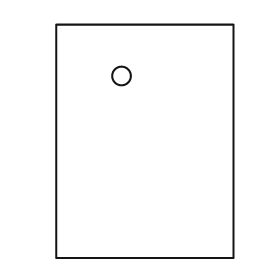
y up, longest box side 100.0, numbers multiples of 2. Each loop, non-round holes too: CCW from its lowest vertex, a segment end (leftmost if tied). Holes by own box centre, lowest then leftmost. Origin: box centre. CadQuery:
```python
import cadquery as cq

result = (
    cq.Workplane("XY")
    .moveTo(-38.0, -50.0)
    .lineTo(38.0, -50.0)
    .lineTo(38.0, 50.0)
    .lineTo(-38.0, 50.0)
    .close()
    .moveTo(-10.0, 28.0)
    .circle(4.0)
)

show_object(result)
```